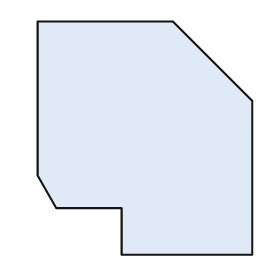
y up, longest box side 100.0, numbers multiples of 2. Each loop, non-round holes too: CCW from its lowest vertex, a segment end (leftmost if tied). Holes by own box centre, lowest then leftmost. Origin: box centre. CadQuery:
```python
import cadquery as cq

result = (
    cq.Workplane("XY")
    .moveTo(-10.0, -50.0)
    .lineTo(46.0, -50.0)
    .lineTo(46.0, 16.0)
    .lineTo(12.0, 50.0)
    .lineTo(-46.0, 50.0)
    .lineTo(-46.0, -16.0)
    .lineTo(-38.0, -30.0)
    .lineTo(-10.0, -30.0)
    .close()
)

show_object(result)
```